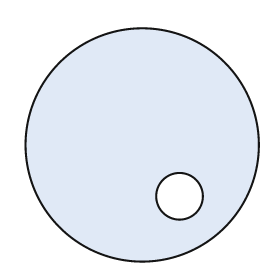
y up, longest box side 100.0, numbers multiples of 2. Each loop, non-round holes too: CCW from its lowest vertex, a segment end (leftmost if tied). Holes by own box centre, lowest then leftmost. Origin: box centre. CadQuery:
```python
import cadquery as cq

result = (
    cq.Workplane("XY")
    .moveTo(0.0, 0.0)
    .circle(50.0)
    .moveTo(16.0, -22.0)
    .circle(10.0)
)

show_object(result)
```